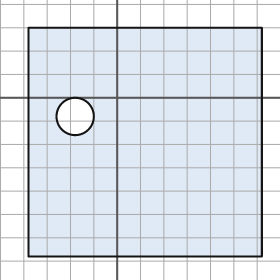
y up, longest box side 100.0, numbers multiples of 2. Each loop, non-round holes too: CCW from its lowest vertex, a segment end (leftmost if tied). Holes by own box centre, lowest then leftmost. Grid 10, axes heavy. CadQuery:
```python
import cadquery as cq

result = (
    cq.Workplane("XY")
    .moveTo(-38.0, -68.0)
    .lineTo(62.0, -68.0)
    .lineTo(62.0, 30.0)
    .lineTo(-38.0, 30.0)
    .close()
    .moveTo(-18.0, -8.0)
    .circle(8.0)
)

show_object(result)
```